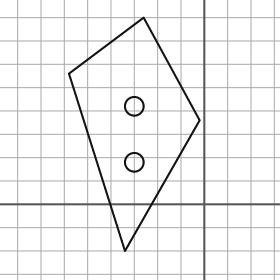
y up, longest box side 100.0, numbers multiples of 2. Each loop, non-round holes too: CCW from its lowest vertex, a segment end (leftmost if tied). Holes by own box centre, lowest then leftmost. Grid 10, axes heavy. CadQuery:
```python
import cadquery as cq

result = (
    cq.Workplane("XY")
    .moveTo(-34.0, -20.0)
    .lineTo(-2.0, 36.0)
    .lineTo(-26.0, 80.0)
    .lineTo(-58.0, 56.0)
    .close()
    .moveTo(-30.0, 18.0)
    .circle(4.0)
    .moveTo(-30.0, 42.0)
    .circle(4.0)
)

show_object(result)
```